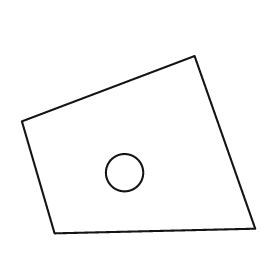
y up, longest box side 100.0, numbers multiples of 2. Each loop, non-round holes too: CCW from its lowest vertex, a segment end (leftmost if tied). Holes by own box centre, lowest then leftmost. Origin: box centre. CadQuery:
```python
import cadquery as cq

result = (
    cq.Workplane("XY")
    .moveTo(-36.0, -38.0)
    .lineTo(50.0, -36.0)
    .lineTo(24.0, 38.0)
    .lineTo(-50.0, 10.0)
    .close()
    .moveTo(-6.0, -12.0)
    .circle(8.0)
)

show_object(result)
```